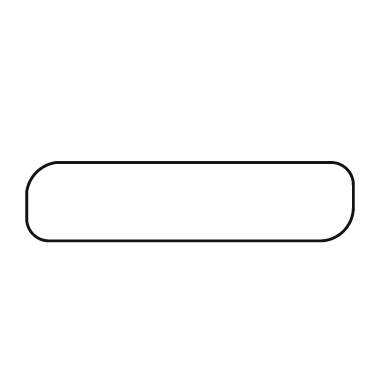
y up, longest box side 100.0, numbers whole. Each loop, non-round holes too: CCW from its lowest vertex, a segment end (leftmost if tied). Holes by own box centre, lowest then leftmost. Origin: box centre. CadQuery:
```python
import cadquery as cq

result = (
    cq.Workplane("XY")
    .moveTo(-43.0, -12.0)
    .lineTo(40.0, -12.0)
    .threePointArc((47.0, -9.0), (50.0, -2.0))
    .lineTo(50.0, 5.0)
    .threePointArc((48.0, 10.0), (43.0, 12.0))
    .lineTo(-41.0, 12.0)
    .threePointArc((-47.0, 9.0), (-50.0, 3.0))
    .lineTo(-50.0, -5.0)
    .threePointArc((-48.0, -10.0), (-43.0, -12.0))
    .close()
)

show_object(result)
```